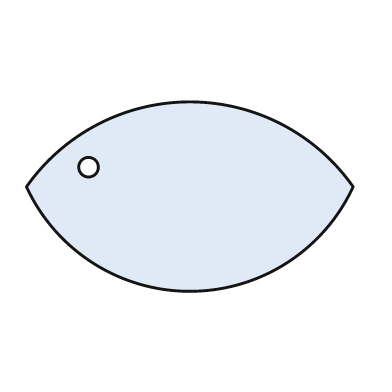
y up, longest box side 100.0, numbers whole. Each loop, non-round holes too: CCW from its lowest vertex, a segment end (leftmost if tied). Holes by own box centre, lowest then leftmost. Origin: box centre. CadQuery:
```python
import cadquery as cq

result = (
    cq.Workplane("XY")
    .moveTo(-50.0, 3.0)
    .threePointArc((0.0, -29.0), (50.0, 3.0))
    .threePointArc((0.0, 29.0), (-50.0, 3.0))
    .close()
    .moveTo(-31.0, 9.0)
    .circle(3.0)
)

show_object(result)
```